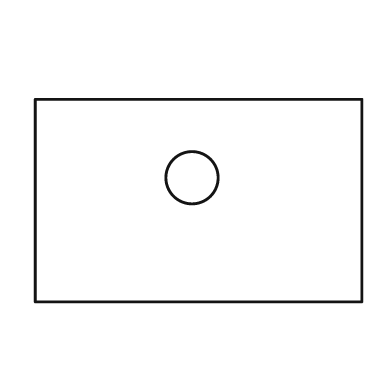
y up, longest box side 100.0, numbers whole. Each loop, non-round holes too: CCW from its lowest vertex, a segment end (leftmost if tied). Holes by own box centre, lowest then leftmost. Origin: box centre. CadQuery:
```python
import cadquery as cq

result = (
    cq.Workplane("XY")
    .moveTo(-50.0, -31.0)
    .lineTo(50.0, -31.0)
    .lineTo(50.0, 31.0)
    .lineTo(-50.0, 31.0)
    .close()
    .moveTo(-2.0, 7.0)
    .circle(8.0)
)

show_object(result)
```